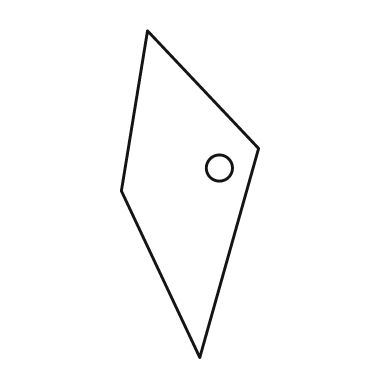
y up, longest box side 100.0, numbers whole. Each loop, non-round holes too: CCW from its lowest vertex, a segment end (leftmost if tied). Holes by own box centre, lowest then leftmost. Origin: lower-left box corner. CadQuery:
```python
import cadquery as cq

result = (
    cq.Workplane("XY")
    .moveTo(24.0, 0.0)
    .lineTo(42.0, 64.0)
    .lineTo(8.0, 100.0)
    .lineTo(0.0, 51.0)
    .close()
    .moveTo(30.0, 58.0)
    .circle(4.0)
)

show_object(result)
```